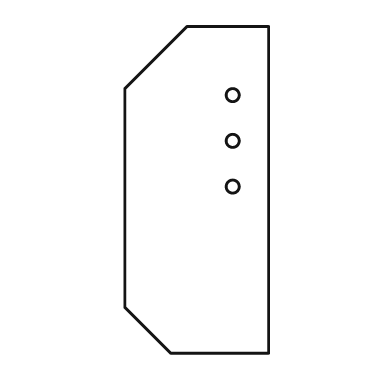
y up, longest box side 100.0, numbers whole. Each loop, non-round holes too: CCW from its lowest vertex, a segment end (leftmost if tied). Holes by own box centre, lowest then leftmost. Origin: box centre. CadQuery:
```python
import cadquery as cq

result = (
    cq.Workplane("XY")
    .moveTo(-8.0, -50.0)
    .lineTo(22.0, -50.0)
    .lineTo(22.0, 50.0)
    .lineTo(-3.0, 50.0)
    .lineTo(-22.0, 31.0)
    .lineTo(-22.0, -36.0)
    .close()
    .moveTo(11.0, 1.0)
    .circle(2.0)
    .moveTo(11.0, 15.0)
    .circle(2.0)
    .moveTo(11.0, 29.0)
    .circle(2.0)
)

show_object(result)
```